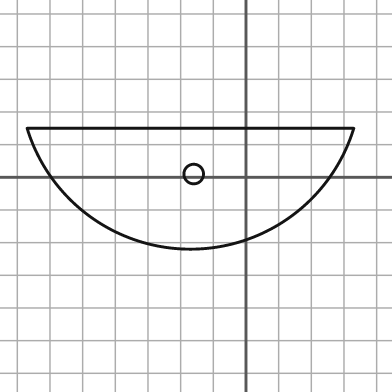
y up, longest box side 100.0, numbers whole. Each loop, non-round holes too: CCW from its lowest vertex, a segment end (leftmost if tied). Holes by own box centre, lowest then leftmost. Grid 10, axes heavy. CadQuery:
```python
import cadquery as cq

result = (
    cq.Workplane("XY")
    .moveTo(-67.0, 15.0)
    .threePointArc((-17.0, -22.0), (33.0, 15.0))
    .close()
    .moveTo(-16.0, 1.0)
    .circle(3.0)
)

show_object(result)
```